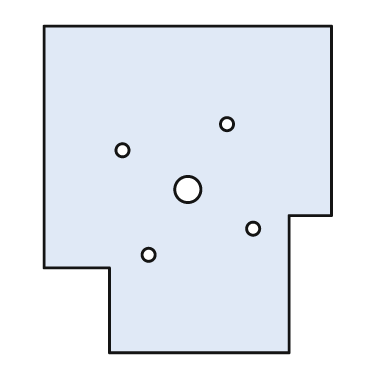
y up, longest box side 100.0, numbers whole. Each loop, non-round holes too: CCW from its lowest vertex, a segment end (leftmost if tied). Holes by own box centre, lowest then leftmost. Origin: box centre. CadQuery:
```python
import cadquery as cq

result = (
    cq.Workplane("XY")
    .moveTo(-24.0, -50.0)
    .lineTo(31.0, -50.0)
    .lineTo(31.0, -8.0)
    .lineTo(44.0, -8.0)
    .lineTo(44.0, 50.0)
    .lineTo(-44.0, 50.0)
    .lineTo(-44.0, -24.0)
    .lineTo(-24.0, -24.0)
    .close()
    .moveTo(-12.0, -20.0)
    .circle(2.0)
    .moveTo(20.0, -12.0)
    .circle(2.0)
    .moveTo(0.0, 0.0)
    .circle(4.0)
    .moveTo(-20.0, 12.0)
    .circle(2.0)
    .moveTo(12.0, 20.0)
    .circle(2.0)
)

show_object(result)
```